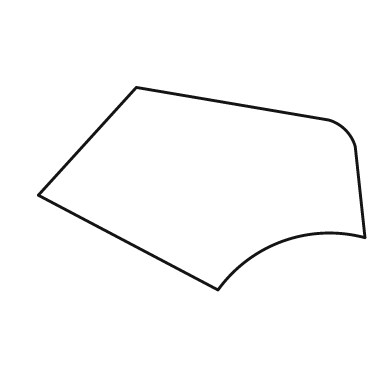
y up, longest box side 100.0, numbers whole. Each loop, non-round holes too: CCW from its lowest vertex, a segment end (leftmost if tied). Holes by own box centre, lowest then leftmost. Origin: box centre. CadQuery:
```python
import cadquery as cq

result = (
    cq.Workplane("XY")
    .moveTo(5.0, -31.0)
    .threePointArc((25.0, -16.0), (50.0, -15.0))
    .lineTo(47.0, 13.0)
    .threePointArc((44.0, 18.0), (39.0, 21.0))
    .lineTo(-20.0, 31.0)
    .lineTo(-50.0, -2.0)
    .close()
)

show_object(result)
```